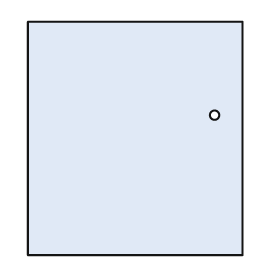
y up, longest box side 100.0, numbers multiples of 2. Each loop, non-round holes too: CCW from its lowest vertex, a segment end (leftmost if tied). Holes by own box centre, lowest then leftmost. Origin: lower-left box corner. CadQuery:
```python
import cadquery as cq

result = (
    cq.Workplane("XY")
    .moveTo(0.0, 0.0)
    .lineTo(92.0, 0.0)
    .lineTo(92.0, 100.0)
    .lineTo(0.0, 100.0)
    .close()
    .moveTo(80.0, 60.0)
    .circle(2.0)
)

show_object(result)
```